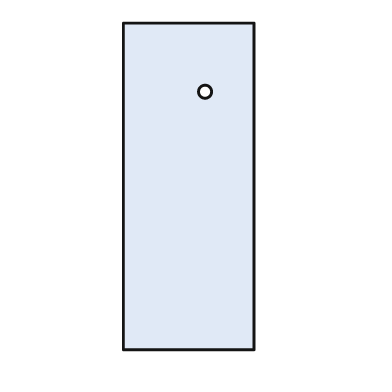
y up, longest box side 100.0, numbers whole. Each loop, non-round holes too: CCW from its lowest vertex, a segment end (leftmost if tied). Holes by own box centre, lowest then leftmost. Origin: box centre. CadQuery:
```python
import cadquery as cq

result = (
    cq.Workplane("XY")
    .moveTo(-20.0, -50.0)
    .lineTo(20.0, -50.0)
    .lineTo(20.0, 50.0)
    .lineTo(-20.0, 50.0)
    .close()
    .moveTo(5.0, 29.0)
    .circle(2.0)
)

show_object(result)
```